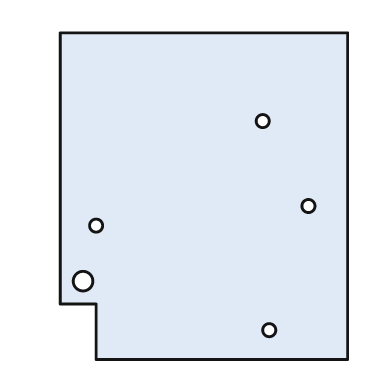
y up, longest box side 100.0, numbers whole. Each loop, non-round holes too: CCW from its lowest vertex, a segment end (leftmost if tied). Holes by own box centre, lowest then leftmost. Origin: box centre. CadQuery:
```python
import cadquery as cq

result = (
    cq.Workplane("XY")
    .moveTo(-33.0, -50.0)
    .lineTo(44.0, -50.0)
    .lineTo(44.0, 50.0)
    .lineTo(-44.0, 50.0)
    .lineTo(-44.0, -33.0)
    .lineTo(-33.0, -33.0)
    .close()
    .moveTo(20.0, -41.0)
    .circle(2.0)
    .moveTo(-37.0, -26.0)
    .circle(3.0)
    .moveTo(-33.0, -9.0)
    .circle(2.0)
    .moveTo(32.0, -3.0)
    .circle(2.0)
    .moveTo(18.0, 23.0)
    .circle(2.0)
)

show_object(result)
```